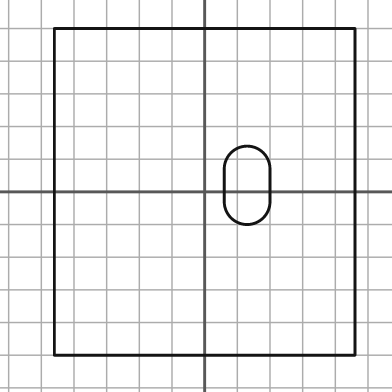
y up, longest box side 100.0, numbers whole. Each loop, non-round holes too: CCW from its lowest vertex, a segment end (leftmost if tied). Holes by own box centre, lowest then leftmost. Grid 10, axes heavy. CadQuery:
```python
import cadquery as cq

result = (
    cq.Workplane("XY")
    .moveTo(-46.0, -50.0)
    .lineTo(46.0, -50.0)
    .lineTo(46.0, 50.0)
    .lineTo(-46.0, 50.0)
    .close()
    .moveTo(6.0, -3.0)
    .threePointArc((13.0, -10.0), (20.0, -3.0))
    .lineTo(20.0, 7.0)
    .threePointArc((13.0, 14.0), (6.0, 7.0))
    .close()
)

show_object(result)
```